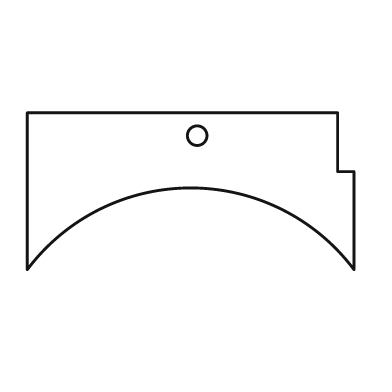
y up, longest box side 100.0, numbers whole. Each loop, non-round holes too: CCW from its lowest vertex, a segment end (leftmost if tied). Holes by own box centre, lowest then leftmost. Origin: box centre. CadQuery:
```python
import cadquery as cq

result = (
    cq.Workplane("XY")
    .moveTo(-50.0, -24.0)
    .threePointArc((0.0, 1.0), (50.0, -24.0))
    .lineTo(50.0, 6.0)
    .lineTo(45.0, 6.0)
    .lineTo(45.0, 24.0)
    .lineTo(-50.0, 24.0)
    .close()
    .moveTo(2.0, 17.0)
    .circle(3.0)
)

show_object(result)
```